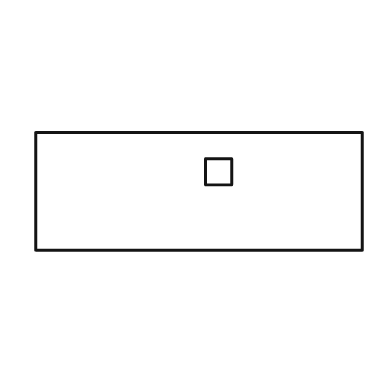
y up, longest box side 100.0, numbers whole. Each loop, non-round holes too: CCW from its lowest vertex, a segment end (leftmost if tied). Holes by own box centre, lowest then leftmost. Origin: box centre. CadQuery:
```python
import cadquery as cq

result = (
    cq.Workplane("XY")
    .moveTo(-50.0, -18.0)
    .lineTo(50.0, -18.0)
    .lineTo(50.0, 18.0)
    .lineTo(-50.0, 18.0)
    .close()
    .moveTo(2.0, 2.0)
    .lineTo(10.0, 2.0)
    .lineTo(10.0, 10.0)
    .lineTo(2.0, 10.0)
    .close()
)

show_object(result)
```